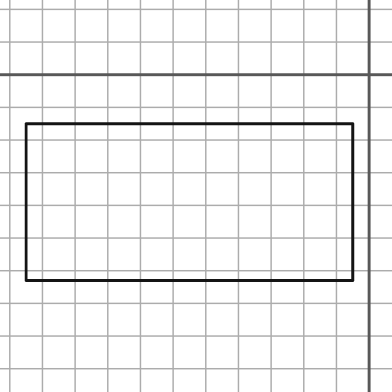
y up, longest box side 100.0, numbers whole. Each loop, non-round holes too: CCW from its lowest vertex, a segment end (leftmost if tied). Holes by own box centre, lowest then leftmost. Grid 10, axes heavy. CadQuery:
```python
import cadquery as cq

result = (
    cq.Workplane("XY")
    .moveTo(-105.0, -63.0)
    .lineTo(-5.0, -63.0)
    .lineTo(-5.0, -15.0)
    .lineTo(-105.0, -15.0)
    .close()
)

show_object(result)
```